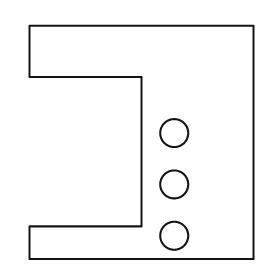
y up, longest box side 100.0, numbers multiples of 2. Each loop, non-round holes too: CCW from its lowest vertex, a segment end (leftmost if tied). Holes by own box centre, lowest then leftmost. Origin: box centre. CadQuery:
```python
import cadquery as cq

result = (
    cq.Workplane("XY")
    .moveTo(-48.0, -50.0)
    .lineTo(48.0, -50.0)
    .lineTo(48.0, 50.0)
    .lineTo(-48.0, 50.0)
    .lineTo(-48.0, 28.0)
    .lineTo(0.0, 28.0)
    .lineTo(0.0, -36.0)
    .lineTo(-48.0, -36.0)
    .close()
    .moveTo(14.0, -40.0)
    .circle(6.0)
    .moveTo(14.0, -18.0)
    .circle(6.0)
    .moveTo(14.0, 4.0)
    .circle(6.0)
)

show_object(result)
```